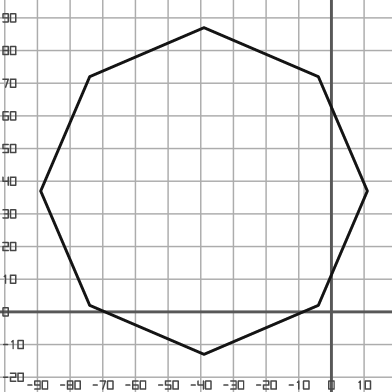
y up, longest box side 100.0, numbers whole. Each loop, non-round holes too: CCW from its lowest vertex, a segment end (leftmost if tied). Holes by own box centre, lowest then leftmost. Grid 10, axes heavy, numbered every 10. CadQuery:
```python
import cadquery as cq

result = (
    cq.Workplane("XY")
    .moveTo(-39.0, -13.0)
    .lineTo(-4.0, 2.0)
    .lineTo(11.0, 37.0)
    .lineTo(-4.0, 72.0)
    .lineTo(-39.0, 87.0)
    .lineTo(-74.0, 72.0)
    .lineTo(-89.0, 37.0)
    .lineTo(-74.0, 2.0)
    .close()
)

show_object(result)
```